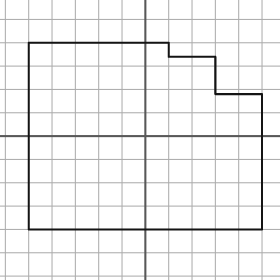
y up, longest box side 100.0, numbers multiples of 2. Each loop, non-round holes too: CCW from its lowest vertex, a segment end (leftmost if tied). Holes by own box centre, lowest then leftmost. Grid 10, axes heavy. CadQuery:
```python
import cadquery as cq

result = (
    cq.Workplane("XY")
    .moveTo(-50.0, -40.0)
    .lineTo(50.0, -40.0)
    .lineTo(50.0, 18.0)
    .lineTo(30.0, 18.0)
    .lineTo(30.0, 34.0)
    .lineTo(10.0, 34.0)
    .lineTo(10.0, 40.0)
    .lineTo(-50.0, 40.0)
    .close()
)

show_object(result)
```